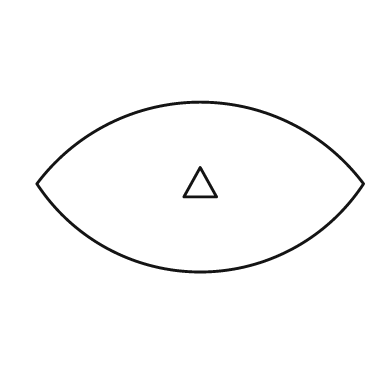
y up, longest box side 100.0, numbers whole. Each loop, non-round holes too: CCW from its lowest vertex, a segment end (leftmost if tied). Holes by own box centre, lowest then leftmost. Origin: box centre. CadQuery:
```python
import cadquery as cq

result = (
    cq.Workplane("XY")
    .moveTo(-50.0, 1.0)
    .threePointArc((0.0, -26.0), (50.0, 1.0))
    .threePointArc((0.0, 26.0), (-50.0, 1.0))
    .close()
    .moveTo(-5.0, -3.0)
    .lineTo(5.0, -3.0)
    .lineTo(0.0, 6.0)
    .close()
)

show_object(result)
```